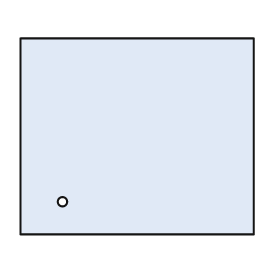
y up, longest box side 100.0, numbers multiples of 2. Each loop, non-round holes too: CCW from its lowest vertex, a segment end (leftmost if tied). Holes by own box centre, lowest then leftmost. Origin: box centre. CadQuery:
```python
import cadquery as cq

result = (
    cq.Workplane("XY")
    .moveTo(-50.0, -42.0)
    .lineTo(50.0, -42.0)
    .lineTo(50.0, 42.0)
    .lineTo(-50.0, 42.0)
    .close()
    .moveTo(-32.0, -28.0)
    .circle(2.0)
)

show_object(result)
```